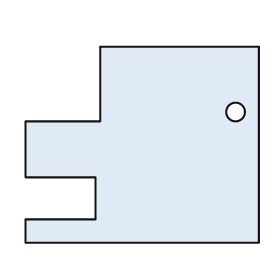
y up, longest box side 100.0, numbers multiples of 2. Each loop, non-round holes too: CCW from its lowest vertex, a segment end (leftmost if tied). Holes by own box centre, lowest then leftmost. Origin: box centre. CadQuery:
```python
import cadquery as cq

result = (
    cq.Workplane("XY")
    .moveTo(-50.0, -42.0)
    .lineTo(50.0, -42.0)
    .lineTo(50.0, 42.0)
    .lineTo(-18.0, 42.0)
    .lineTo(-18.0, 10.0)
    .lineTo(-50.0, 10.0)
    .lineTo(-50.0, -14.0)
    .lineTo(-20.0, -14.0)
    .lineTo(-20.0, -32.0)
    .lineTo(-50.0, -32.0)
    .close()
    .moveTo(40.0, 14.0)
    .circle(4.0)
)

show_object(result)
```